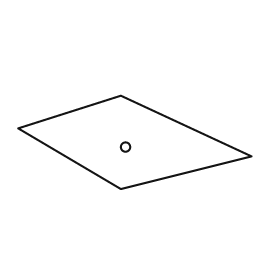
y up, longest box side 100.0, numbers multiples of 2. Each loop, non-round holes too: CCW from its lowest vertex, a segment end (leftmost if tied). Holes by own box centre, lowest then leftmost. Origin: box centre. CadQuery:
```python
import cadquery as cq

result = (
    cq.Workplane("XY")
    .moveTo(-6.0, -20.0)
    .lineTo(50.0, -6.0)
    .lineTo(-6.0, 20.0)
    .lineTo(-50.0, 6.0)
    .close()
    .moveTo(-4.0, -2.0)
    .circle(2.0)
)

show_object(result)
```